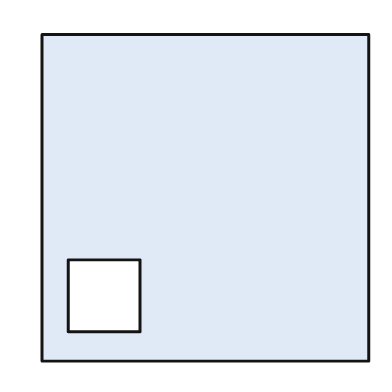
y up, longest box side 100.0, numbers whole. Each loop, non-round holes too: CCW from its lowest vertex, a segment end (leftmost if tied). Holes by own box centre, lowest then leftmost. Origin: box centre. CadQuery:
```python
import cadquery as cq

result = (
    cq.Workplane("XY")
    .moveTo(-50.0, -50.0)
    .lineTo(50.0, -50.0)
    .lineTo(50.0, 50.0)
    .lineTo(-50.0, 50.0)
    .close()
    .moveTo(-42.0, -41.0)
    .lineTo(-20.0, -41.0)
    .lineTo(-20.0, -19.0)
    .lineTo(-42.0, -19.0)
    .close()
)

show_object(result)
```